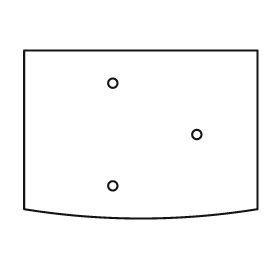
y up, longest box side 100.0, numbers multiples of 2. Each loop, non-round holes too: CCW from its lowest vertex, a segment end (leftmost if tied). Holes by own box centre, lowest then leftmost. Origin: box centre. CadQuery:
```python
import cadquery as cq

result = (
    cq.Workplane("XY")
    .moveTo(-50.0, -32.0)
    .threePointArc((0.0, -36.0), (50.0, -32.0))
    .lineTo(50.0, 36.0)
    .lineTo(-50.0, 36.0)
    .close()
    .moveTo(-12.0, -22.0)
    .circle(2.0)
    .moveTo(24.0, 0.0)
    .circle(2.0)
    .moveTo(-12.0, 22.0)
    .circle(2.0)
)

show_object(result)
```